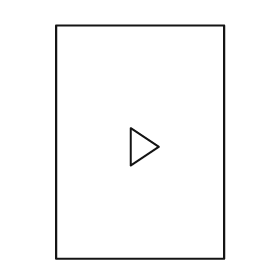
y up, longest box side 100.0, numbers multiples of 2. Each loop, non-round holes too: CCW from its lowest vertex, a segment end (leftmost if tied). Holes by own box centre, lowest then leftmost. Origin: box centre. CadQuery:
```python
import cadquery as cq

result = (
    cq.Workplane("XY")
    .moveTo(-36.0, -50.0)
    .lineTo(36.0, -50.0)
    .lineTo(36.0, 50.0)
    .lineTo(-36.0, 50.0)
    .close()
    .moveTo(-4.0, -10.0)
    .lineTo(8.0, -2.0)
    .lineTo(-4.0, 6.0)
    .close()
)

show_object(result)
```